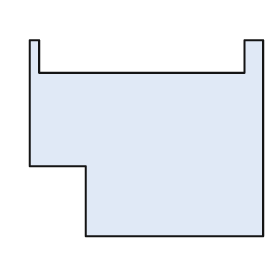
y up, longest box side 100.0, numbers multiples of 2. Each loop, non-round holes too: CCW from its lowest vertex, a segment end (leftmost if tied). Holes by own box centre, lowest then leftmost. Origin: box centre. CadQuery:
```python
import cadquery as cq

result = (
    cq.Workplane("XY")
    .moveTo(-26.0, -42.0)
    .lineTo(50.0, -42.0)
    .lineTo(50.0, 42.0)
    .lineTo(42.0, 42.0)
    .lineTo(42.0, 28.0)
    .lineTo(-46.0, 28.0)
    .lineTo(-46.0, 42.0)
    .lineTo(-50.0, 42.0)
    .lineTo(-50.0, -12.0)
    .lineTo(-26.0, -12.0)
    .close()
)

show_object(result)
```